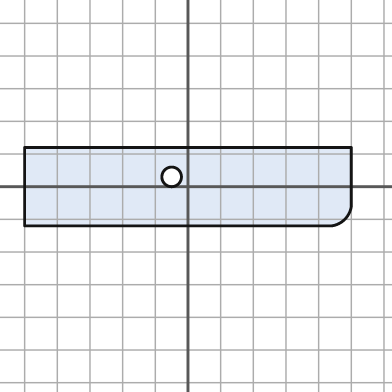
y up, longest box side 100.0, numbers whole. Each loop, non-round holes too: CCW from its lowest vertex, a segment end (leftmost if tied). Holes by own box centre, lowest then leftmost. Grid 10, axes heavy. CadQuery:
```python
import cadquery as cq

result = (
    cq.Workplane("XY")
    .moveTo(-50.0, -12.0)
    .lineTo(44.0, -12.0)
    .threePointArc((48.0, -10.0), (50.0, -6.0))
    .lineTo(50.0, 12.0)
    .lineTo(-50.0, 12.0)
    .close()
    .moveTo(-5.0, 3.0)
    .circle(3.0)
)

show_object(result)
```